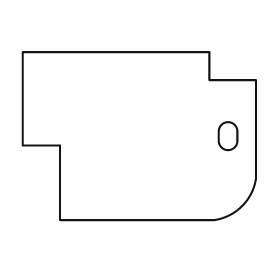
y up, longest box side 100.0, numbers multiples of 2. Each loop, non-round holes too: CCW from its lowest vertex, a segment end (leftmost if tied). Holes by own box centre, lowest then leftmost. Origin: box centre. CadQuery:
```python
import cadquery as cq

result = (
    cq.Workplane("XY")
    .moveTo(-34.0, -36.0)
    .lineTo(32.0, -36.0)
    .threePointArc((44.0, -30.0), (50.0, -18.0))
    .lineTo(50.0, 24.0)
    .lineTo(30.0, 24.0)
    .lineTo(30.0, 36.0)
    .lineTo(-50.0, 36.0)
    .lineTo(-50.0, -4.0)
    .lineTo(-34.0, -4.0)
    .close()
    .moveTo(34.0, -2.0)
    .threePointArc((38.0, -6.0), (42.0, -2.0))
    .lineTo(42.0, 2.0)
    .threePointArc((38.0, 6.0), (34.0, 2.0))
    .close()
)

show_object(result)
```